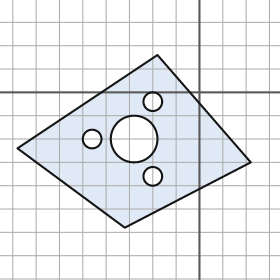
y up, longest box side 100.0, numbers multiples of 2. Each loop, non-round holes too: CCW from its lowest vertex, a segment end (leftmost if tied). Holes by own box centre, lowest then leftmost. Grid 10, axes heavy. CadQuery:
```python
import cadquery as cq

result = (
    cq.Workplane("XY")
    .moveTo(-32.0, -58.0)
    .lineTo(22.0, -30.0)
    .lineTo(-18.0, 16.0)
    .lineTo(-78.0, -24.0)
    .close()
    .moveTo(-20.0, -36.0)
    .circle(4.0)
    .moveTo(-46.0, -20.0)
    .circle(4.0)
    .moveTo(-28.0, -20.0)
    .circle(10.0)
    .moveTo(-20.0, -4.0)
    .circle(4.0)
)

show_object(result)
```